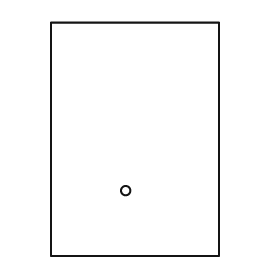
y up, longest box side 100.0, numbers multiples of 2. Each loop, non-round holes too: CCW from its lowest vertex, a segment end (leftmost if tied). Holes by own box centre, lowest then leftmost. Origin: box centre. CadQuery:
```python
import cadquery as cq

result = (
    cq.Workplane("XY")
    .moveTo(-36.0, -50.0)
    .lineTo(36.0, -50.0)
    .lineTo(36.0, 50.0)
    .lineTo(-36.0, 50.0)
    .close()
    .moveTo(-4.0, -22.0)
    .circle(2.0)
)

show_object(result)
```